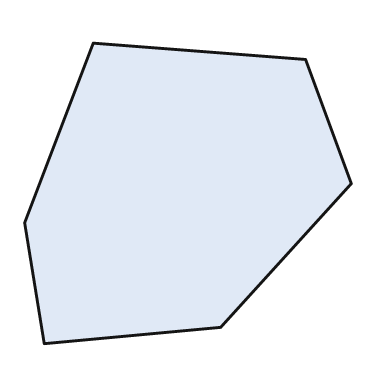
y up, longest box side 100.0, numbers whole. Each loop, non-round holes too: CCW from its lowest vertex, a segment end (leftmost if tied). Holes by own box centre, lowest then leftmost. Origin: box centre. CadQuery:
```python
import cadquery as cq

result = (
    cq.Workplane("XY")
    .moveTo(-44.0, -46.0)
    .lineTo(10.0, -41.0)
    .lineTo(50.0, 3.0)
    .lineTo(36.0, 41.0)
    .lineTo(-29.0, 46.0)
    .lineTo(-50.0, -9.0)
    .close()
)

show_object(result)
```